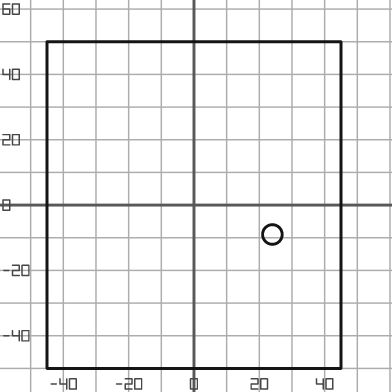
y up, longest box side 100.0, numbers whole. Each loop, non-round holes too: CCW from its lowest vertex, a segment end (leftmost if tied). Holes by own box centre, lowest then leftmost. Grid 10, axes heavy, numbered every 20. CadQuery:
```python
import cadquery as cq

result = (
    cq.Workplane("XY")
    .moveTo(-45.0, -50.0)
    .lineTo(45.0, -50.0)
    .lineTo(45.0, 50.0)
    .lineTo(-45.0, 50.0)
    .close()
    .moveTo(24.0, -9.0)
    .circle(3.0)
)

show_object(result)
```